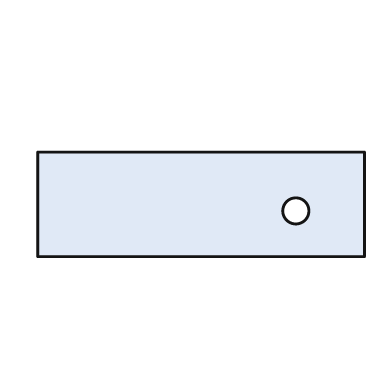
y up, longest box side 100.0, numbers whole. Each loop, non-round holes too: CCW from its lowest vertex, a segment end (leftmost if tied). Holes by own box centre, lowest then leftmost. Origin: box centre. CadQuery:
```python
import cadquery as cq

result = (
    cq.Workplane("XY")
    .moveTo(-50.0, -16.0)
    .lineTo(50.0, -16.0)
    .lineTo(50.0, 16.0)
    .lineTo(-50.0, 16.0)
    .close()
    .moveTo(29.0, -2.0)
    .circle(4.0)
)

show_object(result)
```